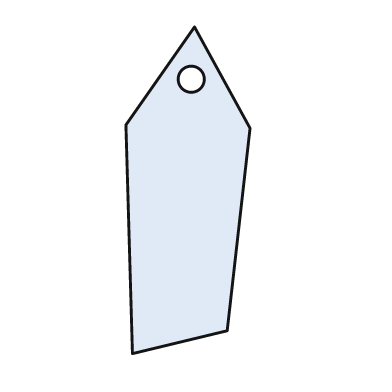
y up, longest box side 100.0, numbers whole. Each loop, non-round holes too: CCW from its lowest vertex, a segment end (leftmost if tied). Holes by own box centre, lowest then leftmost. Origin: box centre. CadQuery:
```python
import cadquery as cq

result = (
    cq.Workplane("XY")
    .moveTo(-17.0, -50.0)
    .lineTo(12.0, -43.0)
    .lineTo(19.0, 19.0)
    .lineTo(2.0, 50.0)
    .lineTo(-19.0, 20.0)
    .close()
    .moveTo(1.0, 34.0)
    .circle(4.0)
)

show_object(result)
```